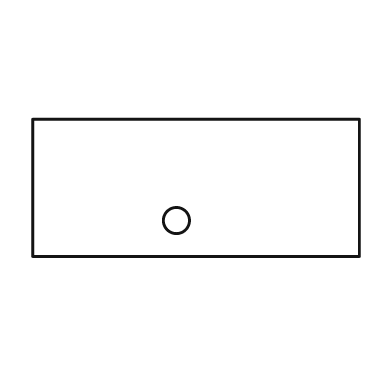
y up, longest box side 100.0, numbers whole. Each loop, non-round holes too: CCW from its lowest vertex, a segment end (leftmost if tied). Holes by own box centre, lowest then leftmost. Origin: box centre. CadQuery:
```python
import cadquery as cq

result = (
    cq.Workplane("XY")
    .moveTo(-50.0, -21.0)
    .lineTo(50.0, -21.0)
    .lineTo(50.0, 21.0)
    .lineTo(-50.0, 21.0)
    .close()
    .moveTo(-6.0, -10.0)
    .circle(4.0)
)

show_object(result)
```